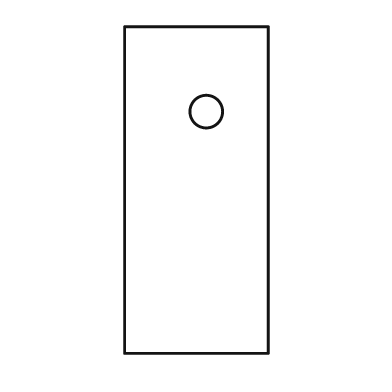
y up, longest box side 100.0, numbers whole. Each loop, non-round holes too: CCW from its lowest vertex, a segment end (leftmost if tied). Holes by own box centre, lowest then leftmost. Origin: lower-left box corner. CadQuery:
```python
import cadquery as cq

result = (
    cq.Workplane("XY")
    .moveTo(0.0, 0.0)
    .lineTo(44.0, 0.0)
    .lineTo(44.0, 100.0)
    .lineTo(0.0, 100.0)
    .close()
    .moveTo(25.0, 74.0)
    .circle(5.0)
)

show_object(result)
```